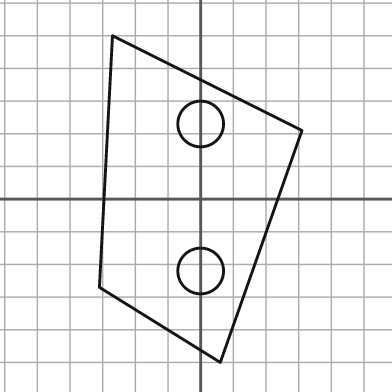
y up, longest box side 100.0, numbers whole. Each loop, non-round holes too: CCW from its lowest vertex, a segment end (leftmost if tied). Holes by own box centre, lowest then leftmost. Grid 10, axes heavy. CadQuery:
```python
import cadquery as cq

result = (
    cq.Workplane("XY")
    .moveTo(6.0, -50.0)
    .lineTo(31.0, 21.0)
    .lineTo(-27.0, 50.0)
    .lineTo(-31.0, -27.0)
    .close()
    .moveTo(0.0, -22.0)
    .circle(7.0)
    .moveTo(0.0, 23.0)
    .circle(7.0)
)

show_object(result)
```